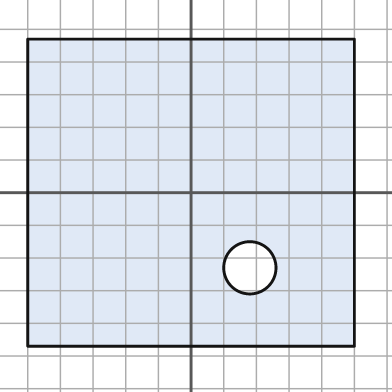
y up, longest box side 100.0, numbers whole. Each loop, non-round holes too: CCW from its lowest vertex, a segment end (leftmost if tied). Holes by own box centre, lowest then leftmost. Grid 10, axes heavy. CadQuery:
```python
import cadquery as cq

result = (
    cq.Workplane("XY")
    .moveTo(-50.0, -47.0)
    .lineTo(50.0, -47.0)
    .lineTo(50.0, 47.0)
    .lineTo(-50.0, 47.0)
    .close()
    .moveTo(18.0, -23.0)
    .circle(8.0)
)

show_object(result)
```